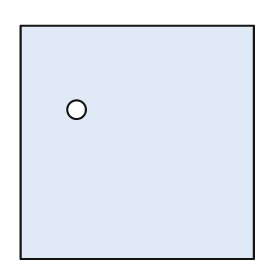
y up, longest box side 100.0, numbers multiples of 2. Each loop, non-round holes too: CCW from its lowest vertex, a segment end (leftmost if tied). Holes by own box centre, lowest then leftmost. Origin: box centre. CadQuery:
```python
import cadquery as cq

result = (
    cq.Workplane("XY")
    .moveTo(-50.0, -50.0)
    .lineTo(50.0, -50.0)
    .lineTo(50.0, 50.0)
    .lineTo(-50.0, 50.0)
    .close()
    .moveTo(-26.0, 14.0)
    .circle(4.0)
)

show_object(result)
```